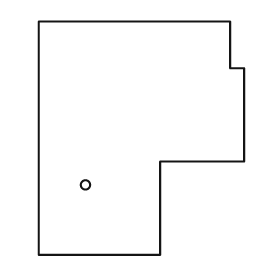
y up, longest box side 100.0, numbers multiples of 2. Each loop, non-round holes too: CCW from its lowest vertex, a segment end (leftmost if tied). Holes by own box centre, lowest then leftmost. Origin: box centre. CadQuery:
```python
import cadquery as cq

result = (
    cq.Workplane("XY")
    .moveTo(-44.0, -50.0)
    .lineTo(8.0, -50.0)
    .lineTo(8.0, -10.0)
    .lineTo(44.0, -10.0)
    .lineTo(44.0, 30.0)
    .lineTo(38.0, 30.0)
    .lineTo(38.0, 50.0)
    .lineTo(-44.0, 50.0)
    .close()
    .moveTo(-24.0, -20.0)
    .circle(2.0)
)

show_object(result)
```